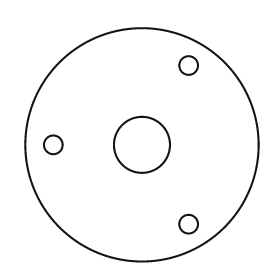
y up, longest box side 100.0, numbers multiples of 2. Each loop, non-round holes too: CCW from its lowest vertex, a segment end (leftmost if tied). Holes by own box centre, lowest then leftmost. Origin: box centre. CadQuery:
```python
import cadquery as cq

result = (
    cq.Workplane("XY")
    .moveTo(0.0, 0.0)
    .circle(50.0)
    .moveTo(20.0, -34.0)
    .circle(4.0)
    .moveTo(-38.0, 0.0)
    .circle(4.0)
    .moveTo(0.0, 0.0)
    .circle(12.0)
    .moveTo(20.0, 34.0)
    .circle(4.0)
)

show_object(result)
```